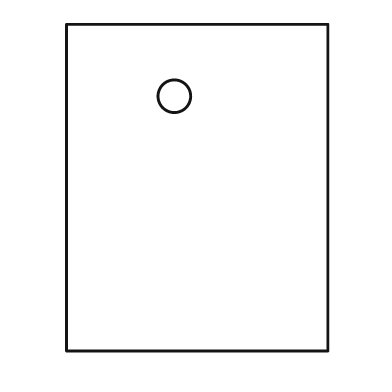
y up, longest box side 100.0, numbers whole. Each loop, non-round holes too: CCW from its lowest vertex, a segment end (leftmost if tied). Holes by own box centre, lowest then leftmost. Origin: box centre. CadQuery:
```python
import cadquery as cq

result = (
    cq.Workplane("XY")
    .moveTo(-40.0, -50.0)
    .lineTo(40.0, -50.0)
    .lineTo(40.0, 50.0)
    .lineTo(-40.0, 50.0)
    .close()
    .moveTo(-7.0, 28.0)
    .circle(5.0)
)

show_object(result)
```